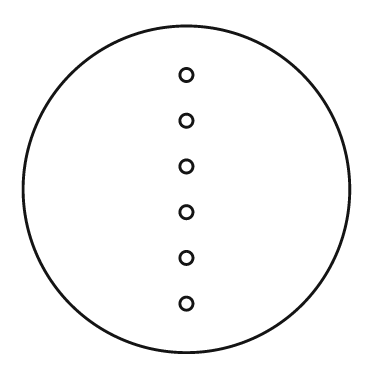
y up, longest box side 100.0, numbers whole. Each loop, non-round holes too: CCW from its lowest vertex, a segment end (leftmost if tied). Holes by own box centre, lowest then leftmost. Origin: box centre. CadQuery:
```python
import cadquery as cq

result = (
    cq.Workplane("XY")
    .moveTo(0.0, 0.0)
    .circle(50.0)
    .moveTo(0.0, -35.0)
    .circle(2.0)
    .moveTo(0.0, -21.0)
    .circle(2.0)
    .moveTo(0.0, -7.0)
    .circle(2.0)
    .moveTo(0.0, 7.0)
    .circle(2.0)
    .moveTo(0.0, 21.0)
    .circle(2.0)
    .moveTo(0.0, 35.0)
    .circle(2.0)
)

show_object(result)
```